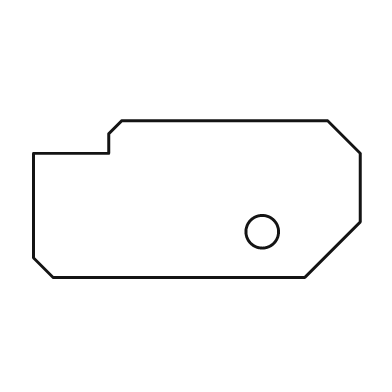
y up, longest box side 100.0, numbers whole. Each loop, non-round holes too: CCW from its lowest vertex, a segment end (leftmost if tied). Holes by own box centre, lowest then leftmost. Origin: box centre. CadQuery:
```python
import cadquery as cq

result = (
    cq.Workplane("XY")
    .moveTo(-44.0, -24.0)
    .lineTo(33.0, -24.0)
    .lineTo(50.0, -7.0)
    .lineTo(50.0, 14.0)
    .lineTo(40.0, 24.0)
    .lineTo(-23.0, 24.0)
    .lineTo(-27.0, 20.0)
    .lineTo(-27.0, 14.0)
    .lineTo(-50.0, 14.0)
    .lineTo(-50.0, -18.0)
    .close()
    .moveTo(20.0, -10.0)
    .circle(5.0)
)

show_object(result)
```